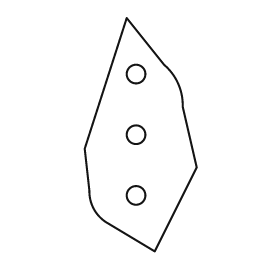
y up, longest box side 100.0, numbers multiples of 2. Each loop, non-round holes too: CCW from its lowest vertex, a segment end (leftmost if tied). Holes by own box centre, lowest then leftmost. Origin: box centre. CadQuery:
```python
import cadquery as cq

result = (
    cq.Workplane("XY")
    .moveTo(6.0, -50.0)
    .lineTo(24.0, -14.0)
    .lineTo(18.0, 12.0)
    .threePointArc((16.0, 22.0), (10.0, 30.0))
    .lineTo(-6.0, 50.0)
    .lineTo(-24.0, -6.0)
    .lineTo(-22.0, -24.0)
    .threePointArc((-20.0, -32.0), (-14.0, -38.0))
    .close()
    .moveTo(-2.0, -26.0)
    .circle(4.0)
    .moveTo(-2.0, 0.0)
    .circle(4.0)
    .moveTo(-2.0, 26.0)
    .circle(4.0)
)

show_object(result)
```